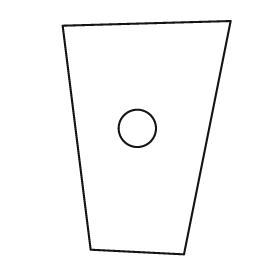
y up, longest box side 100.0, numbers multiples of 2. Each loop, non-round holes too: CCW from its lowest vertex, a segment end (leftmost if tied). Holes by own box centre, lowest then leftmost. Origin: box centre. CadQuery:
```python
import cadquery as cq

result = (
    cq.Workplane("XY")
    .moveTo(16.0, -50.0)
    .lineTo(36.0, 50.0)
    .lineTo(-36.0, 48.0)
    .lineTo(-24.0, -48.0)
    .close()
    .moveTo(-4.0, 4.0)
    .circle(8.0)
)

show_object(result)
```